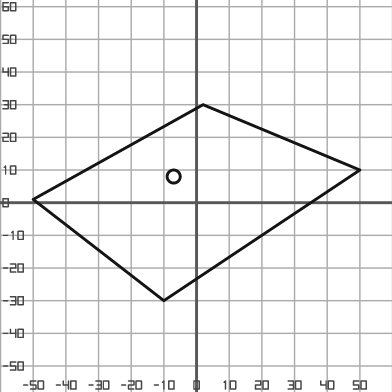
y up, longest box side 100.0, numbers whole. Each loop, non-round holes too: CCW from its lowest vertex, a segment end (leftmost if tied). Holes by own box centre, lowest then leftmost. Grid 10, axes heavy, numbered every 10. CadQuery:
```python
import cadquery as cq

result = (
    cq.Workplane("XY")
    .moveTo(-10.0, -30.0)
    .lineTo(50.0, 10.0)
    .lineTo(2.0, 30.0)
    .lineTo(-50.0, 1.0)
    .close()
    .moveTo(-7.0, 8.0)
    .circle(2.0)
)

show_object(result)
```